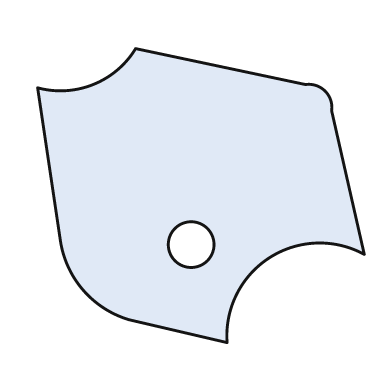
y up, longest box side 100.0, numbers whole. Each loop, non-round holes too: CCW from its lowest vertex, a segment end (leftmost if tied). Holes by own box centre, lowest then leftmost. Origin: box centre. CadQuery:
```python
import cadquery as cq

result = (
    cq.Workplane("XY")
    .moveTo(8.0, -45.0)
    .threePointArc((21.0, -19.0), (50.0, -18.0))
    .lineTo(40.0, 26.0)
    .threePointArc((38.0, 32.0), (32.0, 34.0))
    .lineTo(-20.0, 45.0)
    .threePointArc((-33.0, 34.0), (-50.0, 33.0))
    .lineTo(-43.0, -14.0)
    .threePointArc((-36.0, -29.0), (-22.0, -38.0))
    .close()
    .moveTo(-3.0, -15.0)
    .circle(7.0)
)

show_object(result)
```